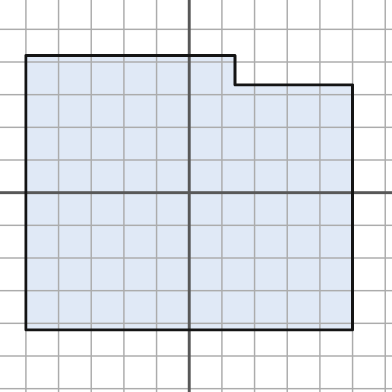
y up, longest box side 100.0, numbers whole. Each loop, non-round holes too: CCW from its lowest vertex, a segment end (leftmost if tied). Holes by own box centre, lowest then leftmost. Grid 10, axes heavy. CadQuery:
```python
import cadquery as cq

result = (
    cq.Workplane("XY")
    .moveTo(-50.0, -42.0)
    .lineTo(50.0, -42.0)
    .lineTo(50.0, 33.0)
    .lineTo(14.0, 33.0)
    .lineTo(14.0, 42.0)
    .lineTo(-50.0, 42.0)
    .close()
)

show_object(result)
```